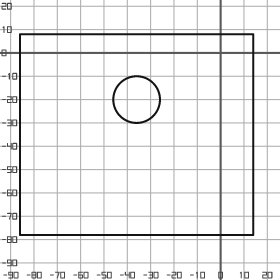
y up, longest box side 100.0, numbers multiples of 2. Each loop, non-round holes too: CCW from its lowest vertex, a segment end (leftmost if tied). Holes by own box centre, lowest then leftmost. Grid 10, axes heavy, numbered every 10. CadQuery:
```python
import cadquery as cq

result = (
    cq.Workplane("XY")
    .moveTo(-86.0, -78.0)
    .lineTo(14.0, -78.0)
    .lineTo(14.0, 8.0)
    .lineTo(-86.0, 8.0)
    .close()
    .moveTo(-36.0, -20.0)
    .circle(10.0)
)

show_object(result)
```